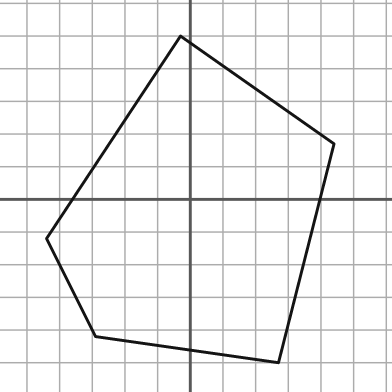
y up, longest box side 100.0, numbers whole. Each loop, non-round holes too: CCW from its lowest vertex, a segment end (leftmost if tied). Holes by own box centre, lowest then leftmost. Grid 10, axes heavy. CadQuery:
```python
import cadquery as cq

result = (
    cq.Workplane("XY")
    .moveTo(27.0, -50.0)
    .lineTo(44.0, 17.0)
    .lineTo(-3.0, 50.0)
    .lineTo(-44.0, -12.0)
    .lineTo(-29.0, -42.0)
    .close()
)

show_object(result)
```